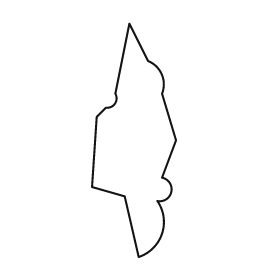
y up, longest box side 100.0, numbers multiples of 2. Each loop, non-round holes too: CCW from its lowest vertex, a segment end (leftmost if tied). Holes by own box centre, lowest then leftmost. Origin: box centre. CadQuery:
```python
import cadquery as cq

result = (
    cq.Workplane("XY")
    .moveTo(2.0, -50.0)
    .threePointArc((12.0, -40.0), (10.0, -26.0))
    .threePointArc((16.0, -22.0), (12.0, -16.0))
    .lineTo(18.0, 0.0)
    .lineTo(12.0, 20.0)
    .threePointArc((12.0, 28.0), (6.0, 34.0))
    .lineTo(-2.0, 50.0)
    .lineTo(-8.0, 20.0)
    .threePointArc((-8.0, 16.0), (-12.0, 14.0))
    .lineTo(-16.0, 10.0)
    .lineTo(-18.0, -20.0)
    .lineTo(-4.0, -24.0)
    .close()
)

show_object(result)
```